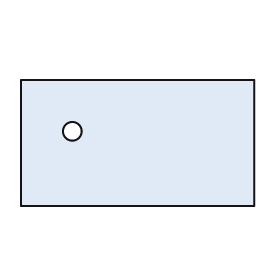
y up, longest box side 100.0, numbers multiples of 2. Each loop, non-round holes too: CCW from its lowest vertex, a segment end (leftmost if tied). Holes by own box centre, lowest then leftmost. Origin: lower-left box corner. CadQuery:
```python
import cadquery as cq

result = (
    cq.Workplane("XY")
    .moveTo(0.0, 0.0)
    .lineTo(100.0, 0.0)
    .lineTo(100.0, 54.0)
    .lineTo(0.0, 54.0)
    .close()
    .moveTo(22.0, 32.0)
    .circle(4.0)
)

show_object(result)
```